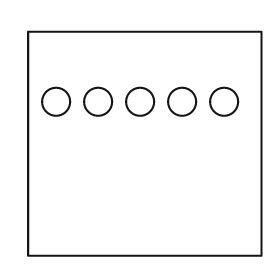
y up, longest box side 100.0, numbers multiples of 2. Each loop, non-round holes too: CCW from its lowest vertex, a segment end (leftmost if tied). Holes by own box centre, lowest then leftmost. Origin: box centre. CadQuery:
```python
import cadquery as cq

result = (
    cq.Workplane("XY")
    .moveTo(-50.0, -48.0)
    .lineTo(50.0, -48.0)
    .lineTo(50.0, 48.0)
    .lineTo(-50.0, 48.0)
    .close()
    .moveTo(-38.0, 18.0)
    .circle(6.0)
    .moveTo(-20.0, 18.0)
    .circle(6.0)
    .moveTo(-2.0, 18.0)
    .circle(6.0)
    .moveTo(16.0, 18.0)
    .circle(6.0)
    .moveTo(34.0, 18.0)
    .circle(6.0)
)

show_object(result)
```